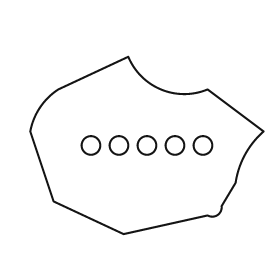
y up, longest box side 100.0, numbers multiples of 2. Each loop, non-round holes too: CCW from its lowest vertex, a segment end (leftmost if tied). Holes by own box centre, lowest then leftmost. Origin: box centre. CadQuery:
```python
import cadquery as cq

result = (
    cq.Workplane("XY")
    .moveTo(-10.0, -38.0)
    .lineTo(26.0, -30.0)
    .threePointArc((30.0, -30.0), (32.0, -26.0))
    .lineTo(38.0, -16.0)
    .threePointArc((42.0, -4.0), (50.0, 6.0))
    .lineTo(26.0, 24.0)
    .threePointArc((6.0, 24.0), (-8.0, 38.0))
    .lineTo(-38.0, 24.0)
    .threePointArc((-46.0, 16.0), (-50.0, 6.0))
    .lineTo(-40.0, -24.0)
    .close()
    .moveTo(-24.0, 0.0)
    .circle(4.0)
    .moveTo(-12.0, 0.0)
    .circle(4.0)
    .moveTo(0.0, 0.0)
    .circle(4.0)
    .moveTo(12.0, 0.0)
    .circle(4.0)
    .moveTo(24.0, 0.0)
    .circle(4.0)
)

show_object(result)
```